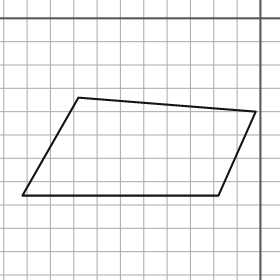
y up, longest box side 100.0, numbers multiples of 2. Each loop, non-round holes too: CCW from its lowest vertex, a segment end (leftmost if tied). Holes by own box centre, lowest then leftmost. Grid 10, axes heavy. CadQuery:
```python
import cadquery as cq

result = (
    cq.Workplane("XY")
    .moveTo(-102.0, -76.0)
    .lineTo(-18.0, -76.0)
    .lineTo(-2.0, -40.0)
    .lineTo(-78.0, -34.0)
    .close()
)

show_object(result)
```